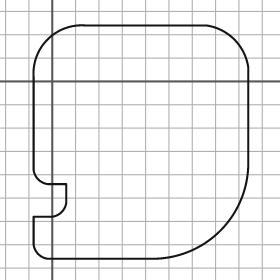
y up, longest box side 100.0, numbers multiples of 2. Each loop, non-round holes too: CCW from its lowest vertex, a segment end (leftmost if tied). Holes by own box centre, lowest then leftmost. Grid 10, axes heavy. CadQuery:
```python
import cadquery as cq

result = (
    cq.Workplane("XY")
    .moveTo(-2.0, -76.0)
    .lineTo(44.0, -76.0)
    .threePointArc((72.0, -64.0), (84.0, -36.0))
    .lineTo(84.0, 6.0)
    .threePointArc((78.0, 18.0), (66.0, 24.0))
    .lineTo(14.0, 24.0)
    .threePointArc((-2.0, 18.0), (-8.0, 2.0))
    .lineTo(-8.0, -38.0)
    .threePointArc((-6.0, -42.0), (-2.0, -44.0))
    .lineTo(6.0, -44.0)
    .lineTo(6.0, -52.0)
    .threePointArc((4.0, -56.0), (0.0, -58.0))
    .lineTo(-8.0, -58.0)
    .lineTo(-8.0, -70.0)
    .threePointArc((-6.0, -74.0), (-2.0, -76.0))
    .close()
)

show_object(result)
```